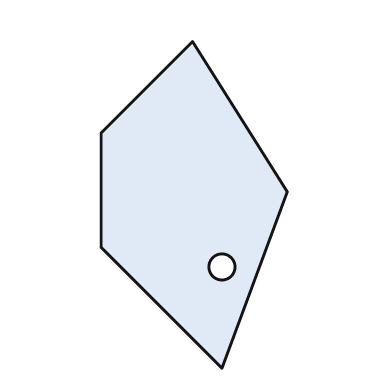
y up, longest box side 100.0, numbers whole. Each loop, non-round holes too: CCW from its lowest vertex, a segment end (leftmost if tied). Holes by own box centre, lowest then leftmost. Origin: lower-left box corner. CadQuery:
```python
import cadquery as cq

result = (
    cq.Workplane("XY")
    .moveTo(37.0, 0.0)
    .lineTo(57.0, 54.0)
    .lineTo(28.0, 100.0)
    .lineTo(0.0, 72.0)
    .lineTo(0.0, 37.0)
    .close()
    .moveTo(37.0, 31.0)
    .circle(4.0)
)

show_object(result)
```